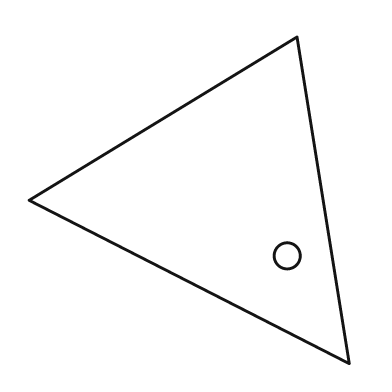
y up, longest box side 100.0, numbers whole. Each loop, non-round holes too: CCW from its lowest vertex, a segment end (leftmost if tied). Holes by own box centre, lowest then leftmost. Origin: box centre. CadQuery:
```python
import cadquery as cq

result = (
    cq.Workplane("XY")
    .moveTo(49.0, -50.0)
    .lineTo(33.0, 50.0)
    .lineTo(-49.0, 0.0)
    .close()
    .moveTo(30.0, -17.0)
    .circle(4.0)
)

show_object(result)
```